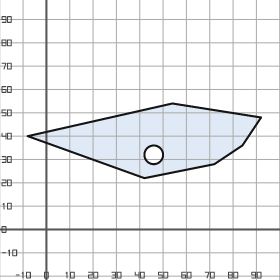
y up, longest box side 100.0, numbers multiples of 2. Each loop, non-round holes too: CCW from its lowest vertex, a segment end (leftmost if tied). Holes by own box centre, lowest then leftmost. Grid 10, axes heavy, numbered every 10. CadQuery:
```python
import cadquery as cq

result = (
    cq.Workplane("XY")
    .moveTo(42.0, 22.0)
    .lineTo(72.0, 28.0)
    .lineTo(84.0, 36.0)
    .lineTo(92.0, 48.0)
    .lineTo(54.0, 54.0)
    .lineTo(-8.0, 40.0)
    .close()
    .moveTo(46.0, 32.0)
    .circle(4.0)
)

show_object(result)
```